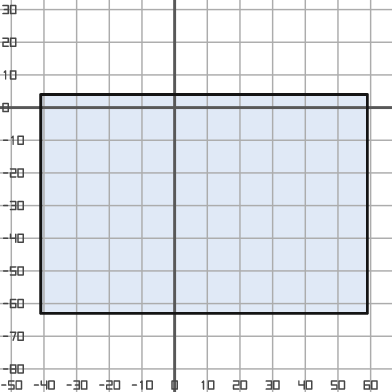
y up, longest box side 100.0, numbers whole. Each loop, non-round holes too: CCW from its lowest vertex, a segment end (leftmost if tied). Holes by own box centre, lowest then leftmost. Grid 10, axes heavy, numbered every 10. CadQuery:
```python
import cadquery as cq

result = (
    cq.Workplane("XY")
    .moveTo(-41.0, -63.0)
    .lineTo(59.0, -63.0)
    .lineTo(59.0, 4.0)
    .lineTo(-41.0, 4.0)
    .close()
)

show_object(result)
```